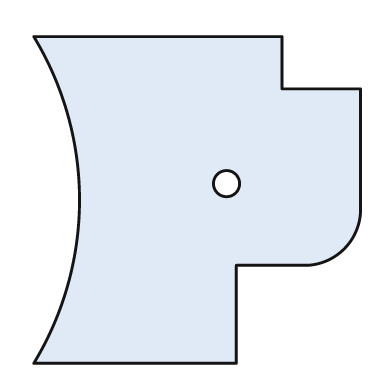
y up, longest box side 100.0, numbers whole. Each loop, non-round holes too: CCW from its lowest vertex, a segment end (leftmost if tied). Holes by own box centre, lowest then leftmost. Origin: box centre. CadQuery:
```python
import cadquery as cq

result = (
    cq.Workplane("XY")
    .moveTo(-50.0, -50.0)
    .lineTo(12.0, -50.0)
    .lineTo(12.0, -20.0)
    .lineTo(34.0, -20.0)
    .threePointArc((45.0, -15.0), (50.0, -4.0))
    .lineTo(50.0, 34.0)
    .lineTo(26.0, 34.0)
    .lineTo(26.0, 50.0)
    .lineTo(-50.0, 50.0)
    .threePointArc((-36.0, 0.0), (-50.0, -50.0))
    .close()
    .moveTo(9.0, 5.0)
    .circle(4.0)
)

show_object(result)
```